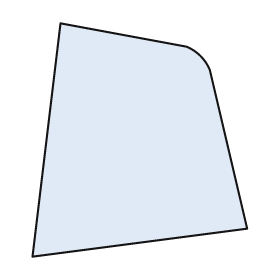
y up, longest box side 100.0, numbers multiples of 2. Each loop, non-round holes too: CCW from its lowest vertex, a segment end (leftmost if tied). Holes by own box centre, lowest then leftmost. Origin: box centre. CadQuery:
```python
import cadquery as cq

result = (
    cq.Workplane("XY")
    .moveTo(-46.0, -50.0)
    .lineTo(46.0, -38.0)
    .lineTo(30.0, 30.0)
    .threePointArc((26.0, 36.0), (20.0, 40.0))
    .lineTo(-34.0, 50.0)
    .close()
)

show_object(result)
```